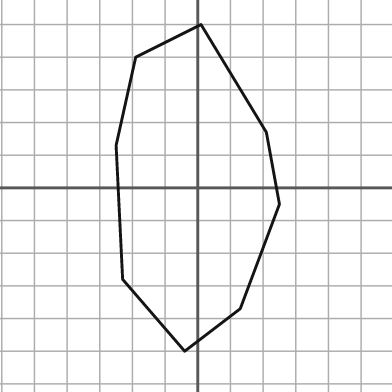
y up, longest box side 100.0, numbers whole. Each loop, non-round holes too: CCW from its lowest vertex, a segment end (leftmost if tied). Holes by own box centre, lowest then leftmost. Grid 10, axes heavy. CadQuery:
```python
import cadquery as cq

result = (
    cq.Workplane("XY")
    .moveTo(-4.0, -50.0)
    .lineTo(13.0, -37.0)
    .lineTo(25.0, -5.0)
    .lineTo(21.0, 17.0)
    .lineTo(1.0, 50.0)
    .lineTo(-19.0, 40.0)
    .lineTo(-25.0, 13.0)
    .lineTo(-23.0, -28.0)
    .close()
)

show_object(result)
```